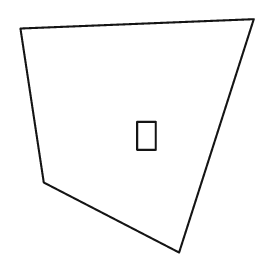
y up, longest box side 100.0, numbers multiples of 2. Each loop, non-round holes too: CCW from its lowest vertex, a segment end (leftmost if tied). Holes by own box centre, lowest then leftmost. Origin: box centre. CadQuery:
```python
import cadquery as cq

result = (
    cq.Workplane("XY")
    .moveTo(18.0, -50.0)
    .lineTo(50.0, 50.0)
    .lineTo(-50.0, 46.0)
    .lineTo(-40.0, -20.0)
    .close()
    .moveTo(0.0, -6.0)
    .lineTo(8.0, -6.0)
    .lineTo(8.0, 6.0)
    .lineTo(0.0, 6.0)
    .close()
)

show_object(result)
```